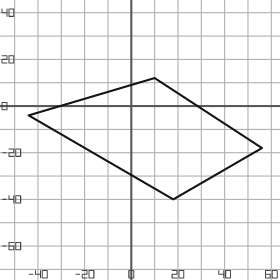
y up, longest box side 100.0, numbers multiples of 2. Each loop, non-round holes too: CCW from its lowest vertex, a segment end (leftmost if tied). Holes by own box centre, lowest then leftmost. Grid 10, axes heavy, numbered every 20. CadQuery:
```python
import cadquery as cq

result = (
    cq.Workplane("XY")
    .moveTo(18.0, -40.0)
    .lineTo(56.0, -18.0)
    .lineTo(10.0, 12.0)
    .lineTo(-44.0, -4.0)
    .close()
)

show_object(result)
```